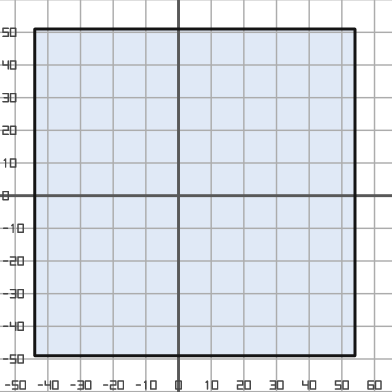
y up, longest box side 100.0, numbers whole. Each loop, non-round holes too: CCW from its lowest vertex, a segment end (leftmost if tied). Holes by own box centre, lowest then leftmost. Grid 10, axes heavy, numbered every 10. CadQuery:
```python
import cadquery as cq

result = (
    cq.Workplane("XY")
    .moveTo(-44.0, -49.0)
    .lineTo(54.0, -49.0)
    .lineTo(54.0, 51.0)
    .lineTo(-44.0, 51.0)
    .close()
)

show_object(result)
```